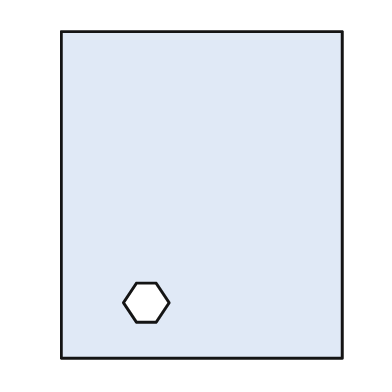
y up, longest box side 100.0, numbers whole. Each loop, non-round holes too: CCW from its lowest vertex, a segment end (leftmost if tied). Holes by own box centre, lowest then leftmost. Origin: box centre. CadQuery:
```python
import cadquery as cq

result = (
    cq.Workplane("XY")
    .moveTo(-43.0, -50.0)
    .lineTo(43.0, -50.0)
    .lineTo(43.0, 50.0)
    .lineTo(-43.0, 50.0)
    .close()
    .moveTo(-20.0, -39.0)
    .lineTo(-14.0, -39.0)
    .lineTo(-10.0, -33.0)
    .lineTo(-14.0, -27.0)
    .lineTo(-20.0, -27.0)
    .lineTo(-24.0, -33.0)
    .close()
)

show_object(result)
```